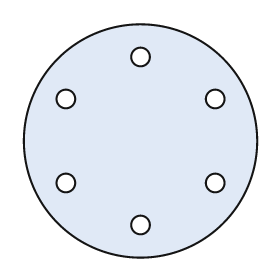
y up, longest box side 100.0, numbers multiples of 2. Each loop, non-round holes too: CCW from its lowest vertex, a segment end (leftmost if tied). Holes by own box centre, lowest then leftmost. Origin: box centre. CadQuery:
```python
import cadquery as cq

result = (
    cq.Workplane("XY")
    .moveTo(0.0, 0.0)
    .circle(50.0)
    .moveTo(0.0, -36.0)
    .circle(4.0)
    .moveTo(-32.0, -18.0)
    .circle(4.0)
    .moveTo(32.0, -18.0)
    .circle(4.0)
    .moveTo(-32.0, 18.0)
    .circle(4.0)
    .moveTo(32.0, 18.0)
    .circle(4.0)
    .moveTo(0.0, 36.0)
    .circle(4.0)
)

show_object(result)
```